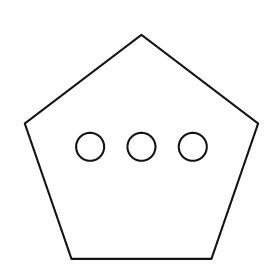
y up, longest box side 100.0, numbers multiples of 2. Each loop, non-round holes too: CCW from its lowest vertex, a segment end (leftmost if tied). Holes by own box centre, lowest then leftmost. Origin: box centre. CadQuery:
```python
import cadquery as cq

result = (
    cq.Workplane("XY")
    .moveTo(-30.0, -48.0)
    .lineTo(30.0, -48.0)
    .lineTo(50.0, 10.0)
    .lineTo(0.0, 48.0)
    .lineTo(-50.0, 10.0)
    .close()
    .moveTo(-22.0, 0.0)
    .circle(6.0)
    .moveTo(0.0, 0.0)
    .circle(6.0)
    .moveTo(22.0, 0.0)
    .circle(6.0)
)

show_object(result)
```